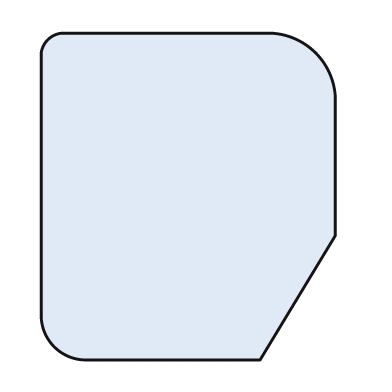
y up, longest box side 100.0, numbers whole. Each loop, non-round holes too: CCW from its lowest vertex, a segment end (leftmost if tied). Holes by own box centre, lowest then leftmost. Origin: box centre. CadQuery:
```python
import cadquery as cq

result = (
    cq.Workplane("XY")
    .moveTo(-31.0, -50.0)
    .lineTo(22.0, -50.0)
    .lineTo(45.0, -12.0)
    .lineTo(45.0, 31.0)
    .threePointArc((39.0, 44.0), (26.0, 50.0))
    .lineTo(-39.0, 50.0)
    .threePointArc((-43.0, 48.0), (-45.0, 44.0))
    .lineTo(-45.0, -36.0)
    .threePointArc((-41.0, -46.0), (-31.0, -50.0))
    .close()
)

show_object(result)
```